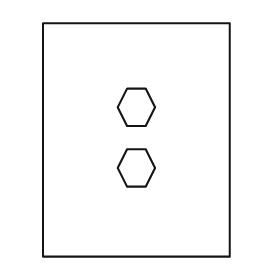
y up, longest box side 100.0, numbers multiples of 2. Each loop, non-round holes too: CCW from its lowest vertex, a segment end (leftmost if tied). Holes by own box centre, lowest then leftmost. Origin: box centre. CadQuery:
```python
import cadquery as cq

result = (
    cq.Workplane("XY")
    .moveTo(-40.0, -50.0)
    .lineTo(40.0, -50.0)
    .lineTo(40.0, 50.0)
    .lineTo(-40.0, 50.0)
    .close()
    .moveTo(-4.0, -20.0)
    .lineTo(4.0, -20.0)
    .lineTo(8.0, -12.0)
    .lineTo(4.0, -4.0)
    .lineTo(-4.0, -4.0)
    .lineTo(-8.0, -12.0)
    .close()
    .moveTo(-4.0, 6.0)
    .lineTo(4.0, 6.0)
    .lineTo(8.0, 14.0)
    .lineTo(4.0, 22.0)
    .lineTo(-4.0, 22.0)
    .lineTo(-8.0, 14.0)
    .close()
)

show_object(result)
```